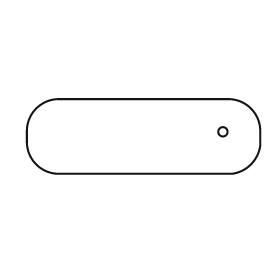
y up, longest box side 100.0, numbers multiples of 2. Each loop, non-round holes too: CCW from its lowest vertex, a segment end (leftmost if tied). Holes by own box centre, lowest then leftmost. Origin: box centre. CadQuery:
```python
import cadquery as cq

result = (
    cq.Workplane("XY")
    .moveTo(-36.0, -16.0)
    .lineTo(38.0, -16.0)
    .threePointArc((46.0, -12.0), (50.0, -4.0))
    .lineTo(50.0, 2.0)
    .threePointArc((46.0, 12.0), (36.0, 16.0))
    .lineTo(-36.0, 16.0)
    .threePointArc((-46.0, 12.0), (-50.0, 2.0))
    .lineTo(-50.0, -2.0)
    .threePointArc((-46.0, -12.0), (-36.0, -16.0))
    .close()
    .moveTo(34.0, 2.0)
    .circle(2.0)
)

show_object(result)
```